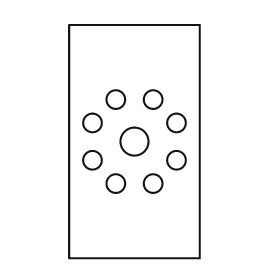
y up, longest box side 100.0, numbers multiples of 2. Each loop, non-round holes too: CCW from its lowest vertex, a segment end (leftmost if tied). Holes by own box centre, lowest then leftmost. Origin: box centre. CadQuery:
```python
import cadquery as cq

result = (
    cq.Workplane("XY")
    .moveTo(-28.0, -50.0)
    .lineTo(28.0, -50.0)
    .lineTo(28.0, 50.0)
    .lineTo(-28.0, 50.0)
    .close()
    .moveTo(-8.0, -18.0)
    .circle(4.0)
    .moveTo(8.0, -18.0)
    .circle(4.0)
    .moveTo(-18.0, -8.0)
    .circle(4.0)
    .moveTo(18.0, -8.0)
    .circle(4.0)
    .moveTo(0.0, 0.0)
    .circle(6.0)
    .moveTo(-18.0, 8.0)
    .circle(4.0)
    .moveTo(18.0, 8.0)
    .circle(4.0)
    .moveTo(-8.0, 18.0)
    .circle(4.0)
    .moveTo(8.0, 18.0)
    .circle(4.0)
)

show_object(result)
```